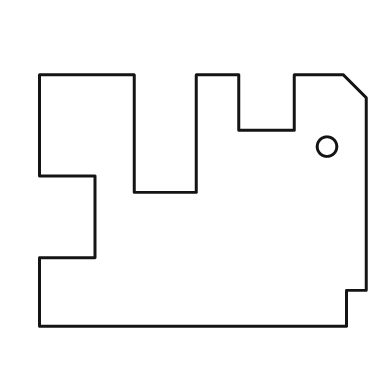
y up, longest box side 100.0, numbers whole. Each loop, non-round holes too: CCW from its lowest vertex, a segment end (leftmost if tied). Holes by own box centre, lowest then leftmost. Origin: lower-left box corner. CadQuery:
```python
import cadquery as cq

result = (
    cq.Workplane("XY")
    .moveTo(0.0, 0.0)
    .lineTo(94.0, 0.0)
    .lineTo(94.0, 11.0)
    .lineTo(100.0, 11.0)
    .lineTo(100.0, 70.0)
    .lineTo(93.0, 77.0)
    .lineTo(78.0, 77.0)
    .lineTo(78.0, 60.0)
    .lineTo(61.0, 60.0)
    .lineTo(61.0, 77.0)
    .lineTo(48.0, 77.0)
    .lineTo(48.0, 41.0)
    .lineTo(29.0, 41.0)
    .lineTo(29.0, 77.0)
    .lineTo(0.0, 77.0)
    .lineTo(0.0, 46.0)
    .lineTo(17.0, 46.0)
    .lineTo(17.0, 21.0)
    .lineTo(0.0, 21.0)
    .close()
    .moveTo(88.0, 55.0)
    .circle(3.0)
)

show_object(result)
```